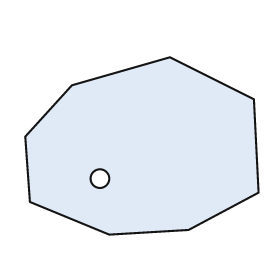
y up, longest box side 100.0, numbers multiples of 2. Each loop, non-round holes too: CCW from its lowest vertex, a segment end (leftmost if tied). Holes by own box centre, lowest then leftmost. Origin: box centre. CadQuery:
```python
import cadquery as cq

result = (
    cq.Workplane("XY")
    .moveTo(-14.0, -38.0)
    .lineTo(20.0, -36.0)
    .lineTo(50.0, -20.0)
    .lineTo(48.0, 20.0)
    .lineTo(12.0, 38.0)
    .lineTo(-30.0, 26.0)
    .lineTo(-50.0, 4.0)
    .lineTo(-48.0, -24.0)
    .close()
    .moveTo(-18.0, -14.0)
    .circle(4.0)
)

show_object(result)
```